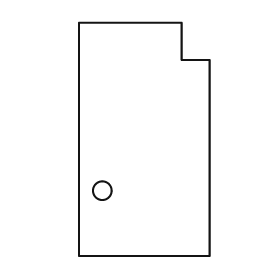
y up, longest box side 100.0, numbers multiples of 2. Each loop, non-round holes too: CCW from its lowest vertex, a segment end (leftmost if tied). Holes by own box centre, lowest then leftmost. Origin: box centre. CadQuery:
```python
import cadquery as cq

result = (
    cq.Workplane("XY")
    .moveTo(-28.0, -50.0)
    .lineTo(28.0, -50.0)
    .lineTo(28.0, 34.0)
    .lineTo(16.0, 34.0)
    .lineTo(16.0, 50.0)
    .lineTo(-28.0, 50.0)
    .close()
    .moveTo(-18.0, -22.0)
    .circle(4.0)
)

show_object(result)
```